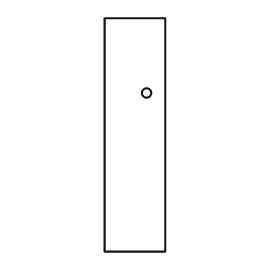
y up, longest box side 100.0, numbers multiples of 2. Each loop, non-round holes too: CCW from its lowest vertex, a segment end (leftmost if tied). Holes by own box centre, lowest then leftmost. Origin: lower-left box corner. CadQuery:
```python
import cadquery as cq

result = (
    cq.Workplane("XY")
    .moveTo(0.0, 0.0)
    .lineTo(26.0, 0.0)
    .lineTo(26.0, 100.0)
    .lineTo(0.0, 100.0)
    .close()
    .moveTo(18.0, 68.0)
    .circle(2.0)
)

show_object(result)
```